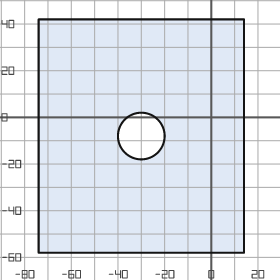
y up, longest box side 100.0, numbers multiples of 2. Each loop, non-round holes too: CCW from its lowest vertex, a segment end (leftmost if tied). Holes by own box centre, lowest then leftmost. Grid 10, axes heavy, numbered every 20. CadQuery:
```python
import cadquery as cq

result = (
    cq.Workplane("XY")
    .moveTo(-74.0, -58.0)
    .lineTo(14.0, -58.0)
    .lineTo(14.0, 42.0)
    .lineTo(-74.0, 42.0)
    .close()
    .moveTo(-30.0, -8.0)
    .circle(10.0)
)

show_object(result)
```